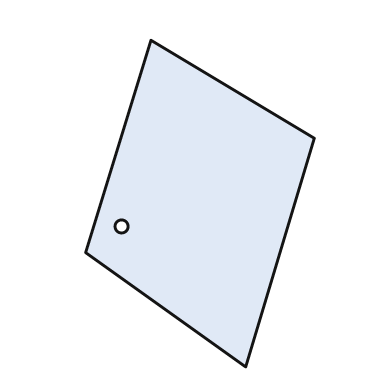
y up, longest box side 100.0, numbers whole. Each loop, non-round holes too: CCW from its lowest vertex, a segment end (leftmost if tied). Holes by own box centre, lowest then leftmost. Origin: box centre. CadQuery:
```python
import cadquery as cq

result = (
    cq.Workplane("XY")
    .moveTo(14.0, -50.0)
    .lineTo(35.0, 20.0)
    .lineTo(-15.0, 50.0)
    .lineTo(-35.0, -15.0)
    .close()
    .moveTo(-24.0, -7.0)
    .circle(2.0)
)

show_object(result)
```